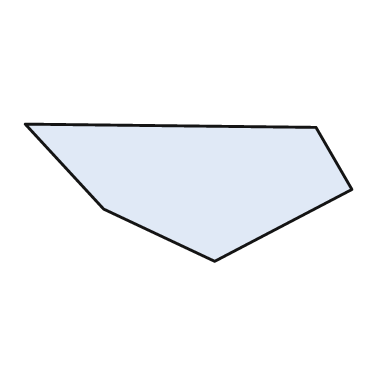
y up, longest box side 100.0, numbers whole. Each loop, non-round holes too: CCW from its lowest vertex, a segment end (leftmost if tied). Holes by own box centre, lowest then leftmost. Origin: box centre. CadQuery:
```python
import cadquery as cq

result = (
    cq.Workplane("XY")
    .moveTo(8.0, -21.0)
    .lineTo(50.0, 1.0)
    .lineTo(39.0, 20.0)
    .lineTo(-50.0, 21.0)
    .lineTo(-26.0, -5.0)
    .close()
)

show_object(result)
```